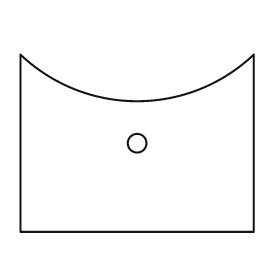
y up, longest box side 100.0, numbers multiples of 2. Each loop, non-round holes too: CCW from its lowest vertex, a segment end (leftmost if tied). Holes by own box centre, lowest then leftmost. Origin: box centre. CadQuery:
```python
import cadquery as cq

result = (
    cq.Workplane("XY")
    .moveTo(-50.0, -38.0)
    .lineTo(50.0, -38.0)
    .lineTo(50.0, 38.0)
    .threePointArc((0.0, 18.0), (-50.0, 38.0))
    .close()
    .moveTo(0.0, 0.0)
    .circle(4.0)
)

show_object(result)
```